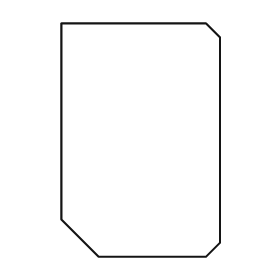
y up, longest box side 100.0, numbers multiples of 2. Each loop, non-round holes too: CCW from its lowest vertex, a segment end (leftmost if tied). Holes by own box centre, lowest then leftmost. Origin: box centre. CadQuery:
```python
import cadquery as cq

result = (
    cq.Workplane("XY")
    .moveTo(-18.0, -50.0)
    .lineTo(28.0, -50.0)
    .lineTo(34.0, -44.0)
    .lineTo(34.0, 44.0)
    .lineTo(28.0, 50.0)
    .lineTo(-34.0, 50.0)
    .lineTo(-34.0, -34.0)
    .close()
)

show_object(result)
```